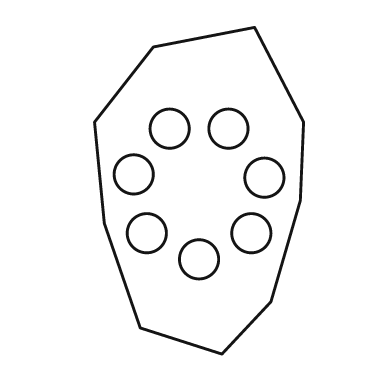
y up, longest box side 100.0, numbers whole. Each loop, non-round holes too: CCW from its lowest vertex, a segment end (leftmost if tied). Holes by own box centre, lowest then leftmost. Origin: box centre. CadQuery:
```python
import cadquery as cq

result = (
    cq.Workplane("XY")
    .moveTo(7.0, -50.0)
    .lineTo(22.0, -34.0)
    .lineTo(31.0, -3.0)
    .lineTo(32.0, 21.0)
    .lineTo(17.0, 50.0)
    .lineTo(-14.0, 44.0)
    .lineTo(-32.0, 21.0)
    .lineTo(-29.0, -10.0)
    .lineTo(-18.0, -42.0)
    .close()
    .moveTo(0.0, -21.0)
    .circle(6.0)
    .moveTo(-16.0, -13.0)
    .circle(6.0)
    .moveTo(16.0, -13.0)
    .circle(6.0)
    .moveTo(20.0, 4.0)
    .circle(6.0)
    .moveTo(-20.0, 5.0)
    .circle(6.0)
    .moveTo(-9.0, 19.0)
    .circle(6.0)
    .moveTo(9.0, 19.0)
    .circle(6.0)
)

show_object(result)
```